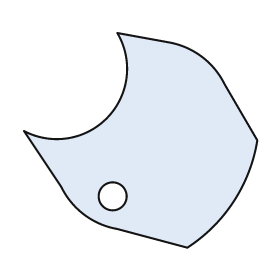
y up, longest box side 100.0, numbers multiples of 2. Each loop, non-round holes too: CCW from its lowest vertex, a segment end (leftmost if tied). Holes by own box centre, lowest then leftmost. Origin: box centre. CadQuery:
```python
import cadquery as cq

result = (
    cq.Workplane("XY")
    .moveTo(20.0, -46.0)
    .threePointArc((40.0, -26.0), (50.0, 0.0))
    .lineTo(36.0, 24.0)
    .threePointArc((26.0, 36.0), (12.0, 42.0))
    .lineTo(-10.0, 46.0)
    .threePointArc((-14.0, 10.0), (-50.0, 4.0))
    .lineTo(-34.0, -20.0)
    .threePointArc((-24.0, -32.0), (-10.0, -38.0))
    .close()
    .moveTo(-12.0, -24.0)
    .circle(6.0)
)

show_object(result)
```